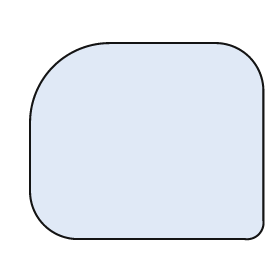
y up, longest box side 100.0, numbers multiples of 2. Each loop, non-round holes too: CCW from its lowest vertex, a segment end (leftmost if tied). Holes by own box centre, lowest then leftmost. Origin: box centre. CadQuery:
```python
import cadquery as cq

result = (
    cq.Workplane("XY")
    .moveTo(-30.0, -42.0)
    .lineTo(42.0, -42.0)
    .threePointArc((48.0, -40.0), (50.0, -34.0))
    .lineTo(50.0, 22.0)
    .threePointArc((44.0, 36.0), (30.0, 42.0))
    .lineTo(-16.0, 42.0)
    .threePointArc((-40.0, 32.0), (-50.0, 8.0))
    .lineTo(-50.0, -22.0)
    .threePointArc((-44.0, -36.0), (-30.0, -42.0))
    .close()
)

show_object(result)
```